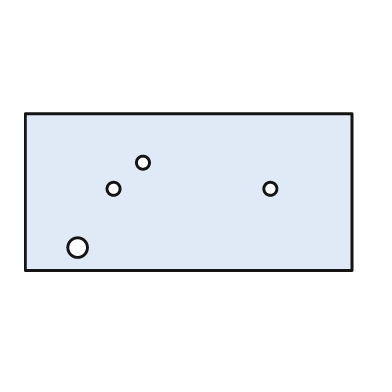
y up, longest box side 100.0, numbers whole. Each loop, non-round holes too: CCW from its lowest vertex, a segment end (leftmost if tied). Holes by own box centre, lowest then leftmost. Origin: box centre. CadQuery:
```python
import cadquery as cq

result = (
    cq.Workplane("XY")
    .moveTo(-50.0, -24.0)
    .lineTo(50.0, -24.0)
    .lineTo(50.0, 24.0)
    .lineTo(-50.0, 24.0)
    .close()
    .moveTo(-34.0, -17.0)
    .circle(3.0)
    .moveTo(-23.0, 1.0)
    .circle(2.0)
    .moveTo(25.0, 1.0)
    .circle(2.0)
    .moveTo(-14.0, 9.0)
    .circle(2.0)
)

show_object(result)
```